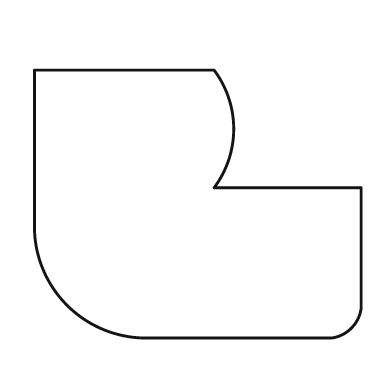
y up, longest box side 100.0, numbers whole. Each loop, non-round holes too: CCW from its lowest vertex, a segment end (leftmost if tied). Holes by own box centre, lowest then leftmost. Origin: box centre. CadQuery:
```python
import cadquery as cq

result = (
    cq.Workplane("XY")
    .moveTo(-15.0, -41.0)
    .lineTo(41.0, -41.0)
    .threePointArc((47.0, -38.0), (50.0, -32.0))
    .lineTo(50.0, 5.0)
    .lineTo(5.0, 5.0)
    .threePointArc((11.0, 23.0), (5.0, 41.0))
    .lineTo(-50.0, 41.0)
    .lineTo(-50.0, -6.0)
    .threePointArc((-40.0, -31.0), (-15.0, -41.0))
    .close()
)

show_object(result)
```